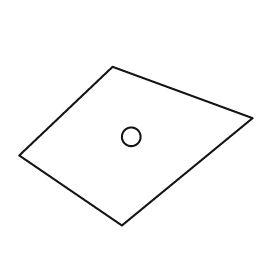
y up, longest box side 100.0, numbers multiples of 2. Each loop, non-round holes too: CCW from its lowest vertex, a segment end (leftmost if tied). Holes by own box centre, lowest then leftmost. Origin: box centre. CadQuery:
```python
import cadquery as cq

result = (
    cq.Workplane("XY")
    .moveTo(-6.0, -34.0)
    .lineTo(50.0, 12.0)
    .lineTo(-10.0, 34.0)
    .lineTo(-50.0, -4.0)
    .close()
    .moveTo(-2.0, 4.0)
    .circle(4.0)
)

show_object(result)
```